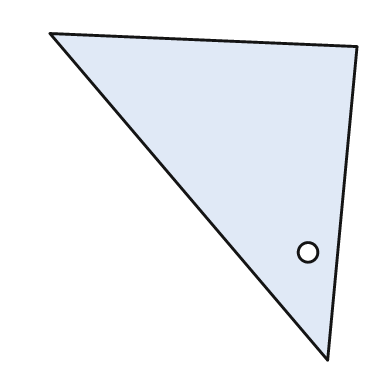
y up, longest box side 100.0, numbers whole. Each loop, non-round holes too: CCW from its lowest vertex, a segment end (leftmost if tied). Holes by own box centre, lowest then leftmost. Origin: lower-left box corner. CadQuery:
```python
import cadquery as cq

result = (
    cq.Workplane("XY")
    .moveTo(85.0, 0.0)
    .lineTo(94.0, 96.0)
    .lineTo(0.0, 100.0)
    .close()
    .moveTo(79.0, 33.0)
    .circle(3.0)
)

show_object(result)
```